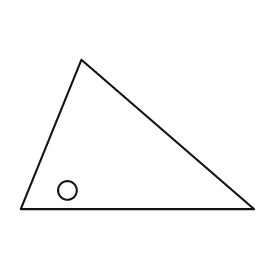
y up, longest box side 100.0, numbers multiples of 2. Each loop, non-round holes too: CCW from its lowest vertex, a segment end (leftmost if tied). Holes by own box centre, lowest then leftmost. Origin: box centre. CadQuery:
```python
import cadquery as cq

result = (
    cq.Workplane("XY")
    .moveTo(-50.0, -32.0)
    .lineTo(50.0, -32.0)
    .lineTo(-24.0, 32.0)
    .close()
    .moveTo(-30.0, -24.0)
    .circle(4.0)
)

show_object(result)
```